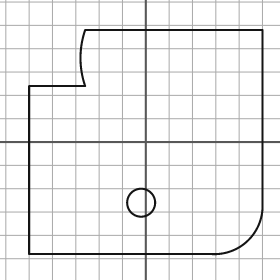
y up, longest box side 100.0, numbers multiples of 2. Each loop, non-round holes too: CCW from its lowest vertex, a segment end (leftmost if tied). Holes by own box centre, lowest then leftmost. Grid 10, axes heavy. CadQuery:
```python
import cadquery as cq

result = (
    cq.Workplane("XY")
    .moveTo(-50.0, -48.0)
    .lineTo(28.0, -48.0)
    .threePointArc((44.0, -42.0), (50.0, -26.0))
    .lineTo(50.0, 48.0)
    .lineTo(-26.0, 48.0)
    .threePointArc((-28.0, 36.0), (-26.0, 24.0))
    .lineTo(-50.0, 24.0)
    .close()
    .moveTo(-2.0, -26.0)
    .circle(6.0)
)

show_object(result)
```